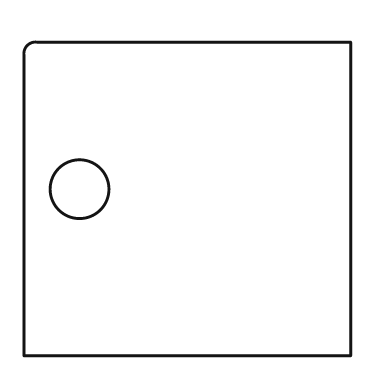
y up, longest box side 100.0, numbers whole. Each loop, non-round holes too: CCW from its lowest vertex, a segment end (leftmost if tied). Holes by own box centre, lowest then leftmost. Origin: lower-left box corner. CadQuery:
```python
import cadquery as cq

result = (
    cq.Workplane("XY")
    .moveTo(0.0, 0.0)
    .lineTo(100.0, 0.0)
    .lineTo(100.0, 96.0)
    .lineTo(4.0, 96.0)
    .threePointArc((1.0, 95.0), (0.0, 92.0))
    .close()
    .moveTo(17.0, 51.0)
    .circle(9.0)
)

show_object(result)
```